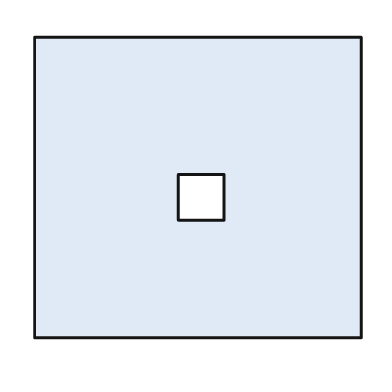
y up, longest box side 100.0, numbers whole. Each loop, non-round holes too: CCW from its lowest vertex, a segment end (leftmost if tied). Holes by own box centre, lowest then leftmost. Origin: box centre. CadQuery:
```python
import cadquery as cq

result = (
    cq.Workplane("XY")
    .moveTo(-50.0, -46.0)
    .lineTo(50.0, -46.0)
    .lineTo(50.0, 46.0)
    .lineTo(-50.0, 46.0)
    .close()
    .moveTo(-6.0, -10.0)
    .lineTo(8.0, -10.0)
    .lineTo(8.0, 4.0)
    .lineTo(-6.0, 4.0)
    .close()
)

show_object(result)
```